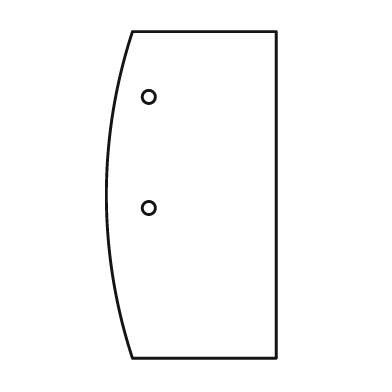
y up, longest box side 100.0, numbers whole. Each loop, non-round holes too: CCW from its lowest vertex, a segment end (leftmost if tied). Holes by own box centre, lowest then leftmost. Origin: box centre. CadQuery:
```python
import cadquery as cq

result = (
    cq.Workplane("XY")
    .moveTo(-18.0, -50.0)
    .lineTo(26.0, -50.0)
    .lineTo(26.0, 50.0)
    .lineTo(-18.0, 50.0)
    .threePointArc((-26.0, 0.0), (-18.0, -50.0))
    .close()
    .moveTo(-13.0, -4.0)
    .circle(2.0)
    .moveTo(-13.0, 30.0)
    .circle(2.0)
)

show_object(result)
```